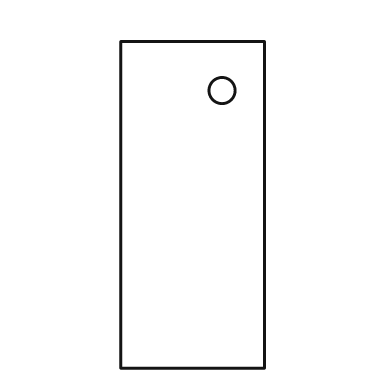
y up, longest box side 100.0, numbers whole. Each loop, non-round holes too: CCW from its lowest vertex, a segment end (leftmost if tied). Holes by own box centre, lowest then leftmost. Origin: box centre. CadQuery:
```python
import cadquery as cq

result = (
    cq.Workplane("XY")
    .moveTo(-22.0, -50.0)
    .lineTo(22.0, -50.0)
    .lineTo(22.0, 50.0)
    .lineTo(-22.0, 50.0)
    .close()
    .moveTo(9.0, 35.0)
    .circle(4.0)
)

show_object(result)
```